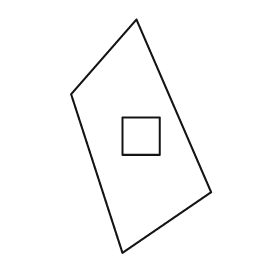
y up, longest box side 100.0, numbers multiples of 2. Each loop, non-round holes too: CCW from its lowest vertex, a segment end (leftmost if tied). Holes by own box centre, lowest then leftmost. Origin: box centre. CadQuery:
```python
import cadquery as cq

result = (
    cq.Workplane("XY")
    .moveTo(-8.0, -50.0)
    .lineTo(30.0, -24.0)
    .lineTo(-2.0, 50.0)
    .lineTo(-30.0, 18.0)
    .close()
    .moveTo(-8.0, -8.0)
    .lineTo(8.0, -8.0)
    .lineTo(8.0, 8.0)
    .lineTo(-8.0, 8.0)
    .close()
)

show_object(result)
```